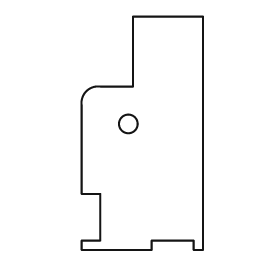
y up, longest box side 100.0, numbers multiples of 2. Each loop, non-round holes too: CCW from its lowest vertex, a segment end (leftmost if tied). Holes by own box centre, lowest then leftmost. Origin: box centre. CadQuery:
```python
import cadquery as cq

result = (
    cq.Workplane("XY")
    .moveTo(-26.0, -50.0)
    .lineTo(4.0, -50.0)
    .lineTo(4.0, -46.0)
    .lineTo(22.0, -46.0)
    .lineTo(22.0, -50.0)
    .lineTo(26.0, -50.0)
    .lineTo(26.0, 50.0)
    .lineTo(-4.0, 50.0)
    .lineTo(-4.0, 20.0)
    .lineTo(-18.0, 20.0)
    .threePointArc((-24.0, 18.0), (-26.0, 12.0))
    .lineTo(-26.0, -26.0)
    .lineTo(-18.0, -26.0)
    .lineTo(-18.0, -46.0)
    .lineTo(-26.0, -46.0)
    .close()
    .moveTo(-6.0, 4.0)
    .circle(4.0)
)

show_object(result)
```